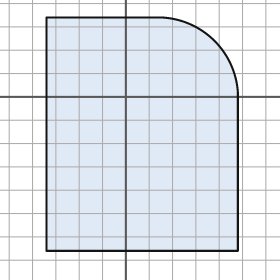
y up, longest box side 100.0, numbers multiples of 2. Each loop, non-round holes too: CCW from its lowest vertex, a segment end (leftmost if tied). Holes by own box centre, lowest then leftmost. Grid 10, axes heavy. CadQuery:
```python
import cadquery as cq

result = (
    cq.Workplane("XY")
    .moveTo(-34.0, -66.0)
    .lineTo(48.0, -66.0)
    .lineTo(48.0, 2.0)
    .threePointArc((38.0, 24.0), (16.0, 34.0))
    .lineTo(-34.0, 34.0)
    .close()
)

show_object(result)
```